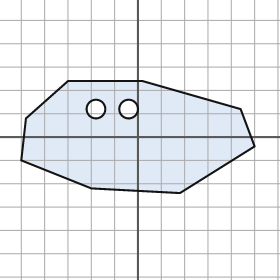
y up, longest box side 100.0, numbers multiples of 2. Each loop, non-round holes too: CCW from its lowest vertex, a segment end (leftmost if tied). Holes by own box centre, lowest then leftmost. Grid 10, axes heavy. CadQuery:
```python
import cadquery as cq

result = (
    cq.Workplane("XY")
    .moveTo(18.0, -24.0)
    .lineTo(50.0, -4.0)
    .lineTo(44.0, 12.0)
    .lineTo(2.0, 24.0)
    .lineTo(-30.0, 24.0)
    .lineTo(-48.0, 8.0)
    .lineTo(-50.0, -10.0)
    .lineTo(-20.0, -22.0)
    .close()
    .moveTo(-18.0, 12.0)
    .circle(4.0)
    .moveTo(-4.0, 12.0)
    .circle(4.0)
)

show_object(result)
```